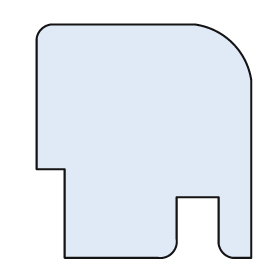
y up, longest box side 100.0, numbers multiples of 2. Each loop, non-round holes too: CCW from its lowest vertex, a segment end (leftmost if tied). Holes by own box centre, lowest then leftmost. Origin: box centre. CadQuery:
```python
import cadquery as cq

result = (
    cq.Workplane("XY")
    .moveTo(-34.0, -50.0)
    .lineTo(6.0, -50.0)
    .threePointArc((12.0, -48.0), (14.0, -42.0))
    .lineTo(14.0, -24.0)
    .lineTo(32.0, -24.0)
    .lineTo(32.0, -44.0)
    .threePointArc((34.0, -48.0), (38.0, -50.0))
    .lineTo(46.0, -50.0)
    .lineTo(46.0, 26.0)
    .threePointArc((38.0, 42.0), (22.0, 50.0))
    .lineTo(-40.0, 50.0)
    .threePointArc((-44.0, 48.0), (-46.0, 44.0))
    .lineTo(-46.0, -12.0)
    .lineTo(-34.0, -12.0)
    .close()
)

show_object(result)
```